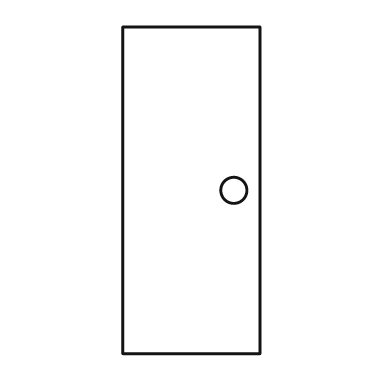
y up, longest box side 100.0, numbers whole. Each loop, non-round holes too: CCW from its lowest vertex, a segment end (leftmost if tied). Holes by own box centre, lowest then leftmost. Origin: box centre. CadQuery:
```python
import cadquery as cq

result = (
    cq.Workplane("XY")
    .moveTo(-21.0, -50.0)
    .lineTo(21.0, -50.0)
    .lineTo(21.0, 50.0)
    .lineTo(-21.0, 50.0)
    .close()
    .moveTo(13.0, 0.0)
    .circle(4.0)
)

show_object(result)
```